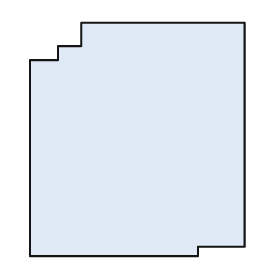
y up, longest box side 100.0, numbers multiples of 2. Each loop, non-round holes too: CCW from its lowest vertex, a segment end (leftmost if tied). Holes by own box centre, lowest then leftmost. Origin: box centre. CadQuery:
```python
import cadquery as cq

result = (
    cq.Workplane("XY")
    .moveTo(-46.0, -50.0)
    .lineTo(26.0, -50.0)
    .lineTo(26.0, -46.0)
    .lineTo(46.0, -46.0)
    .lineTo(46.0, 50.0)
    .lineTo(-24.0, 50.0)
    .lineTo(-24.0, 40.0)
    .lineTo(-34.0, 40.0)
    .lineTo(-34.0, 34.0)
    .lineTo(-46.0, 34.0)
    .close()
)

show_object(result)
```